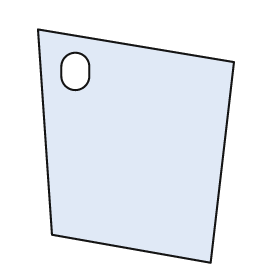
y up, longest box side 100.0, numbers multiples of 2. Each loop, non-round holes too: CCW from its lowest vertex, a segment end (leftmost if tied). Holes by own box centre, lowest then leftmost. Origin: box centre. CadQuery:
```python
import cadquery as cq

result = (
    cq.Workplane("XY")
    .moveTo(32.0, -50.0)
    .lineTo(42.0, 36.0)
    .lineTo(-42.0, 50.0)
    .lineTo(-36.0, -38.0)
    .close()
    .moveTo(-32.0, 30.0)
    .threePointArc((-26.0, 24.0), (-20.0, 30.0))
    .lineTo(-20.0, 34.0)
    .threePointArc((-26.0, 40.0), (-32.0, 34.0))
    .close()
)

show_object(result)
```